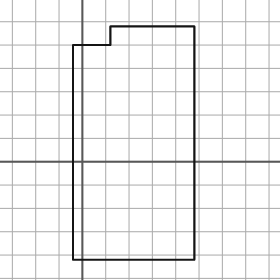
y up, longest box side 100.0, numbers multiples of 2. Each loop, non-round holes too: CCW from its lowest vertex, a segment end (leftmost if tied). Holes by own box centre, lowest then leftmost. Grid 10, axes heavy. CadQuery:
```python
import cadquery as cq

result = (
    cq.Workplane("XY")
    .moveTo(-4.0, -42.0)
    .lineTo(48.0, -42.0)
    .lineTo(48.0, 58.0)
    .lineTo(12.0, 58.0)
    .lineTo(12.0, 50.0)
    .lineTo(-4.0, 50.0)
    .close()
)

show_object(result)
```